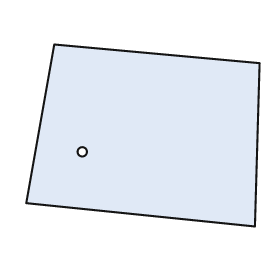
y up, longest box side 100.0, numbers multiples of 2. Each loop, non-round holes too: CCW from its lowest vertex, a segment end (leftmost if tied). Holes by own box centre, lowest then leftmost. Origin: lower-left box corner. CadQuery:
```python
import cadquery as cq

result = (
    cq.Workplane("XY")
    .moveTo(98.0, 0.0)
    .lineTo(100.0, 70.0)
    .lineTo(12.0, 78.0)
    .lineTo(0.0, 10.0)
    .close()
    .moveTo(24.0, 32.0)
    .circle(2.0)
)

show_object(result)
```